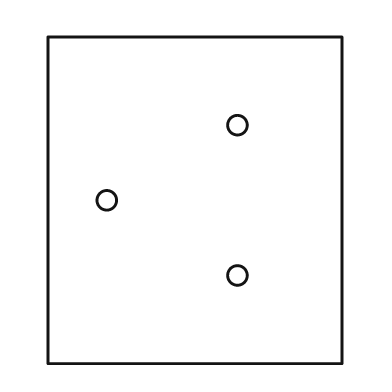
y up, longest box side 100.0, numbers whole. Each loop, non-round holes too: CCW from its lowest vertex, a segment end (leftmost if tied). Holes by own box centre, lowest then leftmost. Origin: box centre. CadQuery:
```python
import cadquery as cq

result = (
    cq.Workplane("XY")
    .moveTo(-45.0, -50.0)
    .lineTo(45.0, -50.0)
    .lineTo(45.0, 50.0)
    .lineTo(-45.0, 50.0)
    .close()
    .moveTo(13.0, -23.0)
    .circle(3.0)
    .moveTo(-27.0, 0.0)
    .circle(3.0)
    .moveTo(13.0, 23.0)
    .circle(3.0)
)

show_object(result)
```